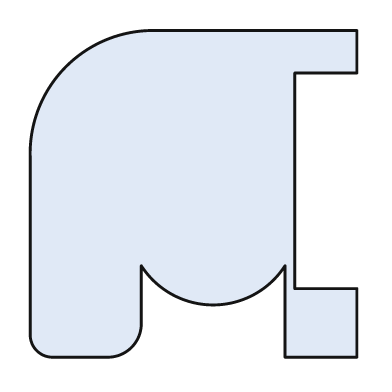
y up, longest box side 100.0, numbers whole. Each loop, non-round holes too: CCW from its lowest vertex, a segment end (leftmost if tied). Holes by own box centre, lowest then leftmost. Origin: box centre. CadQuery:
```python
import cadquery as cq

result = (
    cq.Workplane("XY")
    .moveTo(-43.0, -50.0)
    .lineTo(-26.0, -50.0)
    .threePointArc((-19.0, -47.0), (-16.0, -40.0))
    .lineTo(-16.0, -22.0)
    .threePointArc((6.0, -34.0), (28.0, -22.0))
    .lineTo(28.0, -50.0)
    .lineTo(50.0, -50.0)
    .lineTo(50.0, -29.0)
    .lineTo(31.0, -29.0)
    .lineTo(31.0, 37.0)
    .lineTo(50.0, 37.0)
    .lineTo(50.0, 50.0)
    .lineTo(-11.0, 50.0)
    .threePointArc((-39.0, 39.0), (-50.0, 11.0))
    .lineTo(-50.0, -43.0)
    .threePointArc((-48.0, -48.0), (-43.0, -50.0))
    .close()
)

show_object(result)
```